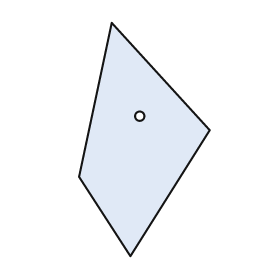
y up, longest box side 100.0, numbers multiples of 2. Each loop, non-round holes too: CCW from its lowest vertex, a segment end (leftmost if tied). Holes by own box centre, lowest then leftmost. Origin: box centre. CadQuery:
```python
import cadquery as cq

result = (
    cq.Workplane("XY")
    .moveTo(-6.0, -50.0)
    .lineTo(28.0, 4.0)
    .lineTo(-14.0, 50.0)
    .lineTo(-28.0, -16.0)
    .close()
    .moveTo(-2.0, 10.0)
    .circle(2.0)
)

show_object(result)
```